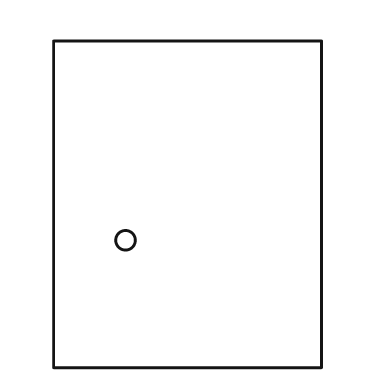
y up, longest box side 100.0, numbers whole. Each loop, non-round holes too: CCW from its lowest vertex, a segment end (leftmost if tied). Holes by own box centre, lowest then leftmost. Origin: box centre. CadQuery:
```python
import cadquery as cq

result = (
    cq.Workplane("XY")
    .moveTo(-41.0, -50.0)
    .lineTo(41.0, -50.0)
    .lineTo(41.0, 50.0)
    .lineTo(-41.0, 50.0)
    .close()
    .moveTo(-19.0, -11.0)
    .circle(3.0)
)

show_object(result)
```